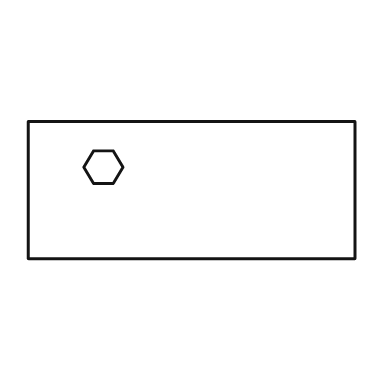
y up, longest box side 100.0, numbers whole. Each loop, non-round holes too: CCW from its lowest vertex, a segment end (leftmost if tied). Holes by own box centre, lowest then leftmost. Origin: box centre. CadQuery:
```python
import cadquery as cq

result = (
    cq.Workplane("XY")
    .moveTo(-50.0, -21.0)
    .lineTo(50.0, -21.0)
    .lineTo(50.0, 21.0)
    .lineTo(-50.0, 21.0)
    .close()
    .moveTo(-30.0, 2.0)
    .lineTo(-24.0, 2.0)
    .lineTo(-21.0, 7.0)
    .lineTo(-24.0, 12.0)
    .lineTo(-30.0, 12.0)
    .lineTo(-33.0, 7.0)
    .close()
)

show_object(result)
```